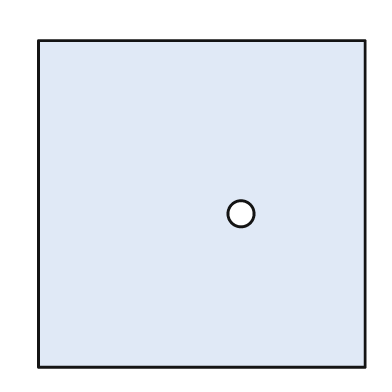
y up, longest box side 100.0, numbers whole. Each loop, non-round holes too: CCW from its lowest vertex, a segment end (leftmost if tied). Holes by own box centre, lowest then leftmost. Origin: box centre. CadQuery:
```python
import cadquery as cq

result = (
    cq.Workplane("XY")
    .moveTo(-50.0, -50.0)
    .lineTo(50.0, -50.0)
    .lineTo(50.0, 50.0)
    .lineTo(-50.0, 50.0)
    .close()
    .moveTo(12.0, -3.0)
    .circle(4.0)
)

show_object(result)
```